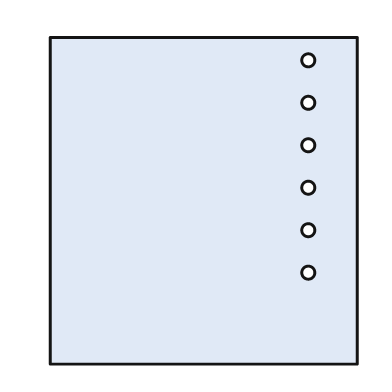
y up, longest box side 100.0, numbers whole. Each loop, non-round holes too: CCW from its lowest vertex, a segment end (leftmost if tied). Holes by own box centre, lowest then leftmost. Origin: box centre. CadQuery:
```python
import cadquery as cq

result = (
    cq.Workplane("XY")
    .moveTo(-47.0, -50.0)
    .lineTo(47.0, -50.0)
    .lineTo(47.0, 50.0)
    .lineTo(-47.0, 50.0)
    .close()
    .moveTo(32.0, -22.0)
    .circle(2.0)
    .moveTo(32.0, -9.0)
    .circle(2.0)
    .moveTo(32.0, 4.0)
    .circle(2.0)
    .moveTo(32.0, 17.0)
    .circle(2.0)
    .moveTo(32.0, 30.0)
    .circle(2.0)
    .moveTo(32.0, 43.0)
    .circle(2.0)
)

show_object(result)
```